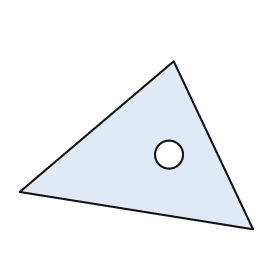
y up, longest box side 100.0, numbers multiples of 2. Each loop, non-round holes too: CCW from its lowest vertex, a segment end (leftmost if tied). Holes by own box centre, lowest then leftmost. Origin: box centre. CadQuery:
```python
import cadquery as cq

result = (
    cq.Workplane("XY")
    .moveTo(50.0, -36.0)
    .lineTo(16.0, 36.0)
    .lineTo(-50.0, -20.0)
    .close()
    .moveTo(14.0, -4.0)
    .circle(6.0)
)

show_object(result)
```